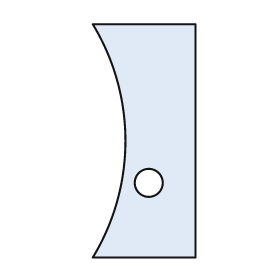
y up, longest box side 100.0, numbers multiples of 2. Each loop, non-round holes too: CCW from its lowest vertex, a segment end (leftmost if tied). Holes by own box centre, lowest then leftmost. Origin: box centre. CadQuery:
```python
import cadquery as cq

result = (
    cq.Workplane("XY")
    .moveTo(-22.0, -50.0)
    .lineTo(22.0, -50.0)
    .lineTo(22.0, 50.0)
    .lineTo(-22.0, 50.0)
    .threePointArc((-8.0, 0.0), (-22.0, -50.0))
    .close()
    .moveTo(2.0, -18.0)
    .circle(6.0)
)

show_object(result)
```